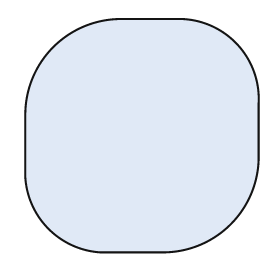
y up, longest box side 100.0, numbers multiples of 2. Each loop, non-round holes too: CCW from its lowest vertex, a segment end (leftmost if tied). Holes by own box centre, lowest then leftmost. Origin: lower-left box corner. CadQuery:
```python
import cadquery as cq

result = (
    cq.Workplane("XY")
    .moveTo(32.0, 0.0)
    .lineTo(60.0, 0.0)
    .threePointArc((88.0, 12.0), (100.0, 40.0))
    .lineTo(100.0, 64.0)
    .threePointArc((90.0, 90.0), (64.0, 100.0))
    .lineTo(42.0, 100.0)
    .threePointArc((12.0, 88.0), (0.0, 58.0))
    .lineTo(0.0, 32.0)
    .threePointArc((10.0, 10.0), (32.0, 0.0))
    .close()
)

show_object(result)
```